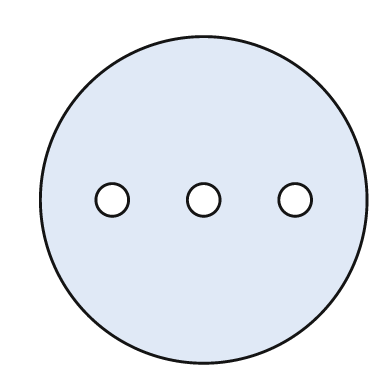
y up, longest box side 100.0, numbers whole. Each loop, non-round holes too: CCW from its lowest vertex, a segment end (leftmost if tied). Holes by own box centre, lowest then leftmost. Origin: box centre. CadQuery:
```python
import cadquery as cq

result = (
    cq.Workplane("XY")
    .moveTo(0.0, 0.0)
    .circle(50.0)
    .moveTo(-28.0, 0.0)
    .circle(5.0)
    .moveTo(0.0, 0.0)
    .circle(5.0)
    .moveTo(28.0, 0.0)
    .circle(5.0)
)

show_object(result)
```